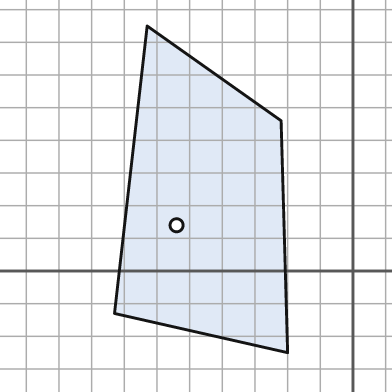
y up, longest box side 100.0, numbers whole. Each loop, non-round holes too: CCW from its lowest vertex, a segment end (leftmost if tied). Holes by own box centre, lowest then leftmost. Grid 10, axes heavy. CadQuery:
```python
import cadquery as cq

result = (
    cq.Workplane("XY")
    .moveTo(-20.0, -25.0)
    .lineTo(-22.0, 46.0)
    .lineTo(-63.0, 75.0)
    .lineTo(-73.0, -13.0)
    .close()
    .moveTo(-54.0, 14.0)
    .circle(2.0)
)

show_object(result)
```